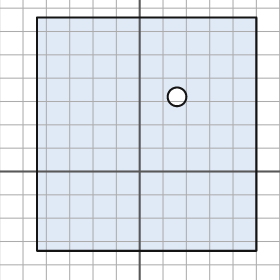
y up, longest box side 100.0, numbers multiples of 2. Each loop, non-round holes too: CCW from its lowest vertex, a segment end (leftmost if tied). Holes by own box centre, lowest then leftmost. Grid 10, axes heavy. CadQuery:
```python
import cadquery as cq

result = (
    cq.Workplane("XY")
    .moveTo(-44.0, -34.0)
    .lineTo(50.0, -34.0)
    .lineTo(50.0, 66.0)
    .lineTo(-44.0, 66.0)
    .close()
    .moveTo(16.0, 32.0)
    .circle(4.0)
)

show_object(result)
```